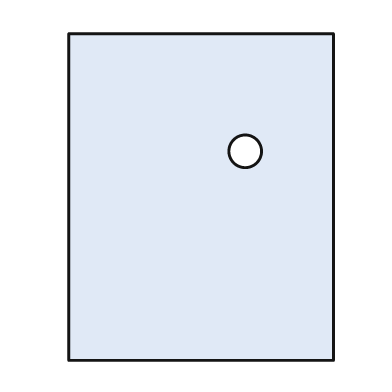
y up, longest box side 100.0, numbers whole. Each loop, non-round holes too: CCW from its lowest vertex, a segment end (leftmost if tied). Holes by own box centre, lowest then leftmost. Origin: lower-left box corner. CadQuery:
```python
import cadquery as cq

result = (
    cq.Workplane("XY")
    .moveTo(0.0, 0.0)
    .lineTo(81.0, 0.0)
    .lineTo(81.0, 100.0)
    .lineTo(0.0, 100.0)
    .close()
    .moveTo(54.0, 64.0)
    .circle(5.0)
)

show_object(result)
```